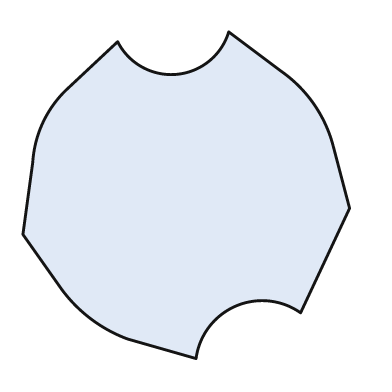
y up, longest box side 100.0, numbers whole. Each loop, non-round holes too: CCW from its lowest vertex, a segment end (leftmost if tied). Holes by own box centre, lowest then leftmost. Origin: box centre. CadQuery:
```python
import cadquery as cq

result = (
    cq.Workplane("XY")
    .moveTo(3.0, -50.0)
    .threePointArc((15.0, -34.0), (35.0, -36.0))
    .lineTo(50.0, -4.0)
    .lineTo(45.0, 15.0)
    .threePointArc((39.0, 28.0), (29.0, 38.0))
    .lineTo(13.0, 50.0)
    .threePointArc((-3.0, 37.0), (-21.0, 47.0))
    .lineTo(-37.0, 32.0)
    .threePointArc((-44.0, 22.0), (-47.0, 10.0))
    .lineTo(-50.0, -12.0)
    .lineTo(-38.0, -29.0)
    .threePointArc((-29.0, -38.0), (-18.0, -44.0))
    .close()
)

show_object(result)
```